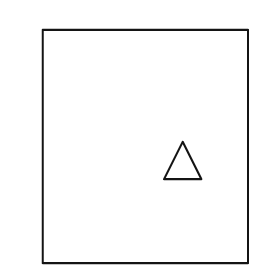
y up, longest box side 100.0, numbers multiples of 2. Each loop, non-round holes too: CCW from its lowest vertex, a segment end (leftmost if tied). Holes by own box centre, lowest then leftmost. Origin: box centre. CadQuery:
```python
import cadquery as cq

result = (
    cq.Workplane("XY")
    .moveTo(-44.0, -50.0)
    .lineTo(44.0, -50.0)
    .lineTo(44.0, 50.0)
    .lineTo(-44.0, 50.0)
    .close()
    .moveTo(8.0, -14.0)
    .lineTo(24.0, -14.0)
    .lineTo(16.0, 2.0)
    .close()
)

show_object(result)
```